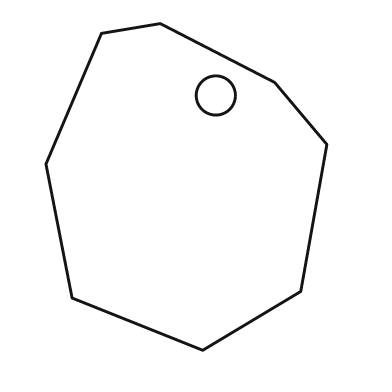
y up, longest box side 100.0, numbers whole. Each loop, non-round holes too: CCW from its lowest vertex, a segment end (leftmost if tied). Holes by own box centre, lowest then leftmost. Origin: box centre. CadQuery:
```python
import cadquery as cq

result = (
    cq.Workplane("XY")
    .moveTo(5.0, -50.0)
    .lineTo(35.0, -32.0)
    .lineTo(43.0, 13.0)
    .lineTo(27.0, 32.0)
    .lineTo(-8.0, 50.0)
    .lineTo(-26.0, 47.0)
    .lineTo(-43.0, 7.0)
    .lineTo(-35.0, -34.0)
    .close()
    .moveTo(9.0, 28.0)
    .circle(6.0)
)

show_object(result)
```